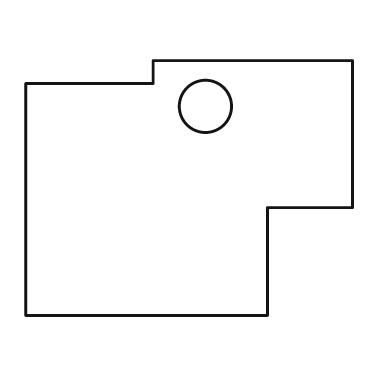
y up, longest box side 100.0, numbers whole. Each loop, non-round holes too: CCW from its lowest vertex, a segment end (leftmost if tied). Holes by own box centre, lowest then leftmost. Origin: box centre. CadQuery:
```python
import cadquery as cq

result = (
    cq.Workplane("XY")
    .moveTo(-50.0, -39.0)
    .lineTo(24.0, -39.0)
    .lineTo(24.0, -6.0)
    .lineTo(50.0, -6.0)
    .lineTo(50.0, 39.0)
    .lineTo(-11.0, 39.0)
    .lineTo(-11.0, 32.0)
    .lineTo(-50.0, 32.0)
    .close()
    .moveTo(5.0, 25.0)
    .circle(8.0)
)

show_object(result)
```